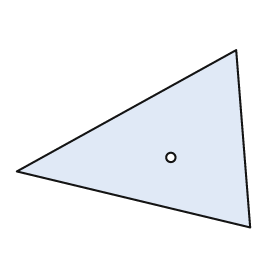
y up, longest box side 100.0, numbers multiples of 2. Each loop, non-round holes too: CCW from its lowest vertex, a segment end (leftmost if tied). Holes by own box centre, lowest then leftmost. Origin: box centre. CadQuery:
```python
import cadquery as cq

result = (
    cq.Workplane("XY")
    .moveTo(50.0, -38.0)
    .lineTo(44.0, 38.0)
    .lineTo(-50.0, -14.0)
    .close()
    .moveTo(16.0, -8.0)
    .circle(2.0)
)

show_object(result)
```